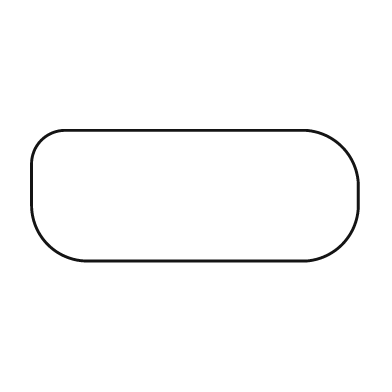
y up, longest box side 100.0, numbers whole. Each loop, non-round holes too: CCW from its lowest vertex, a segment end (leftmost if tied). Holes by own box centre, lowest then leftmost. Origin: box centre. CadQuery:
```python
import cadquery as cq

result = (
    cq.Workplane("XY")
    .moveTo(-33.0, -20.0)
    .lineTo(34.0, -20.0)
    .threePointArc((45.0, -15.0), (50.0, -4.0))
    .lineTo(50.0, 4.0)
    .threePointArc((45.0, 15.0), (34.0, 20.0))
    .lineTo(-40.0, 20.0)
    .threePointArc((-47.0, 17.0), (-50.0, 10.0))
    .lineTo(-50.0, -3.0)
    .threePointArc((-45.0, -15.0), (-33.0, -20.0))
    .close()
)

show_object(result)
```